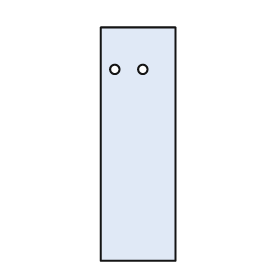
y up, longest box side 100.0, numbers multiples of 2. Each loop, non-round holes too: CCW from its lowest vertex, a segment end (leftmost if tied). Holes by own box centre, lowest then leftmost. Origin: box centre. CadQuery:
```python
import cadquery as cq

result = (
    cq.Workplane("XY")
    .moveTo(-16.0, -50.0)
    .lineTo(16.0, -50.0)
    .lineTo(16.0, 50.0)
    .lineTo(-16.0, 50.0)
    .close()
    .moveTo(-10.0, 32.0)
    .circle(2.0)
    .moveTo(2.0, 32.0)
    .circle(2.0)
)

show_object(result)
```